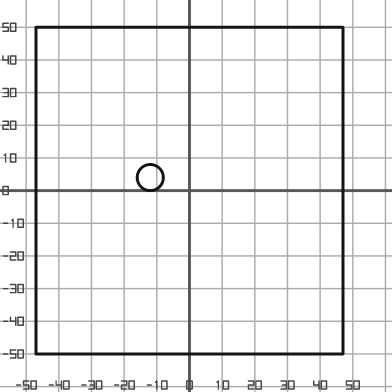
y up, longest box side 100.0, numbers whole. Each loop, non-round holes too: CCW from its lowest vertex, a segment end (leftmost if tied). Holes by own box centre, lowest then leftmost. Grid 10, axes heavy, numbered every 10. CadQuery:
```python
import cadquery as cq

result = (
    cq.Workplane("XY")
    .moveTo(-47.0, -50.0)
    .lineTo(47.0, -50.0)
    .lineTo(47.0, 50.0)
    .lineTo(-47.0, 50.0)
    .close()
    .moveTo(-12.0, 4.0)
    .circle(4.0)
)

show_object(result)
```